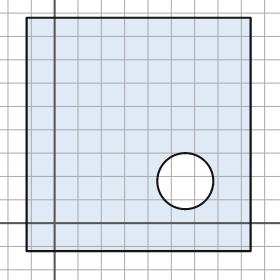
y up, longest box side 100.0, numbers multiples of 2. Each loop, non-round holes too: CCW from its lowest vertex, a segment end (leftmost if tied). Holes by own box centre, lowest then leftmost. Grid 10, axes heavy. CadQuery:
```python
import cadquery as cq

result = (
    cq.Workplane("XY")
    .moveTo(-12.0, -12.0)
    .lineTo(84.0, -12.0)
    .lineTo(84.0, 88.0)
    .lineTo(-12.0, 88.0)
    .close()
    .moveTo(56.0, 18.0)
    .circle(12.0)
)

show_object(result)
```